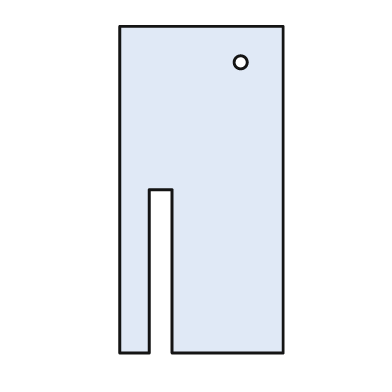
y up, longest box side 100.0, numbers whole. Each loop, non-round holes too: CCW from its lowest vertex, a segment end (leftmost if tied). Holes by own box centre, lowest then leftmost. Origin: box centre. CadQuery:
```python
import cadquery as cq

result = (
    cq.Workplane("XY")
    .moveTo(-25.0, -50.0)
    .lineTo(-16.0, -50.0)
    .lineTo(-16.0, 0.0)
    .lineTo(-9.0, 0.0)
    .lineTo(-9.0, -50.0)
    .lineTo(25.0, -50.0)
    .lineTo(25.0, 50.0)
    .lineTo(-25.0, 50.0)
    .close()
    .moveTo(12.0, 39.0)
    .circle(2.0)
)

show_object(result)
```